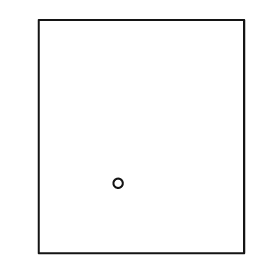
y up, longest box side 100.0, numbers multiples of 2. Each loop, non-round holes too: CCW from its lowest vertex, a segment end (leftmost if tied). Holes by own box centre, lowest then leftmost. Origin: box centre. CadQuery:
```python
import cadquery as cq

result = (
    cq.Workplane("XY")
    .moveTo(-44.0, -50.0)
    .lineTo(44.0, -50.0)
    .lineTo(44.0, 50.0)
    .lineTo(-44.0, 50.0)
    .close()
    .moveTo(-10.0, -20.0)
    .circle(2.0)
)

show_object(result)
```